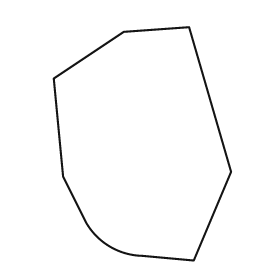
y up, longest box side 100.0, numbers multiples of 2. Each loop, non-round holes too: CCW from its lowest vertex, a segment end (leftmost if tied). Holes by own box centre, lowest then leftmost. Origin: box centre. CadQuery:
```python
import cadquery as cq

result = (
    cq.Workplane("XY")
    .moveTo(22.0, -50.0)
    .lineTo(38.0, -12.0)
    .lineTo(20.0, 50.0)
    .lineTo(-8.0, 48.0)
    .lineTo(-38.0, 28.0)
    .lineTo(-34.0, -14.0)
    .lineTo(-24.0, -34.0)
    .threePointArc((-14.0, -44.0), (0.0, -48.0))
    .close()
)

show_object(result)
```